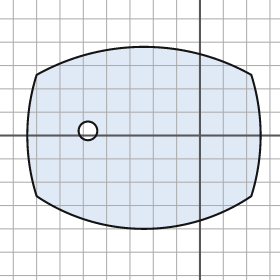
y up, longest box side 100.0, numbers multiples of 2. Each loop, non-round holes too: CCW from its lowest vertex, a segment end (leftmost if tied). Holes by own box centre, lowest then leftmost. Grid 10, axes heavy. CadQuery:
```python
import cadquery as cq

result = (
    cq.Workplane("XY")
    .moveTo(-70.0, -26.0)
    .threePointArc((-24.0, -40.0), (22.0, -26.0))
    .threePointArc((26.0, 0.0), (22.0, 26.0))
    .threePointArc((-24.0, 38.0), (-70.0, 26.0))
    .threePointArc((-74.0, 0.0), (-70.0, -26.0))
    .close()
    .moveTo(-48.0, 2.0)
    .circle(4.0)
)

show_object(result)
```